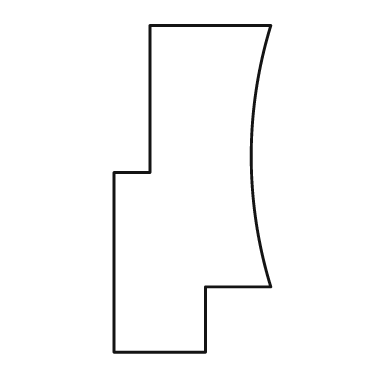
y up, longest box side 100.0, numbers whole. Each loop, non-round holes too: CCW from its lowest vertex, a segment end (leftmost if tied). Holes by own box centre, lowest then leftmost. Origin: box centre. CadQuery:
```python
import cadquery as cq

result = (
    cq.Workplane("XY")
    .moveTo(-24.0, -50.0)
    .lineTo(4.0, -50.0)
    .lineTo(4.0, -30.0)
    .lineTo(24.0, -30.0)
    .threePointArc((18.0, 10.0), (24.0, 50.0))
    .lineTo(-13.0, 50.0)
    .lineTo(-13.0, 5.0)
    .lineTo(-24.0, 5.0)
    .close()
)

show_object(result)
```